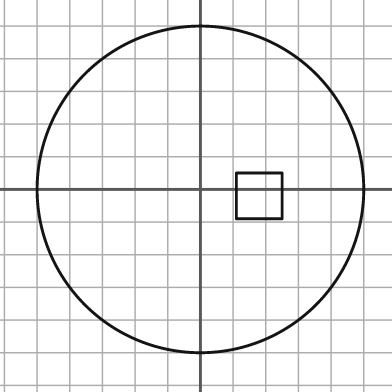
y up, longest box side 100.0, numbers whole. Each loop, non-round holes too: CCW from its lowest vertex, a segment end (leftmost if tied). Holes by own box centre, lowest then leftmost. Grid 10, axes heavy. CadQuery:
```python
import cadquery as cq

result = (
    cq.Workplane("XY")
    .moveTo(0.0, 0.0)
    .circle(50.0)
    .moveTo(11.0, -9.0)
    .lineTo(25.0, -9.0)
    .lineTo(25.0, 5.0)
    .lineTo(11.0, 5.0)
    .close()
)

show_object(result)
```